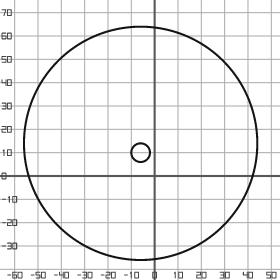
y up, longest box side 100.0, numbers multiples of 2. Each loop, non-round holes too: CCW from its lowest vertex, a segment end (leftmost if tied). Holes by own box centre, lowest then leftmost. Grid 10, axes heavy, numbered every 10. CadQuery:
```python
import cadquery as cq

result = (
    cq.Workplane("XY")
    .moveTo(-6.0, 14.0)
    .circle(50.0)
    .moveTo(-6.0, 10.0)
    .circle(4.0)
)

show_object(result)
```